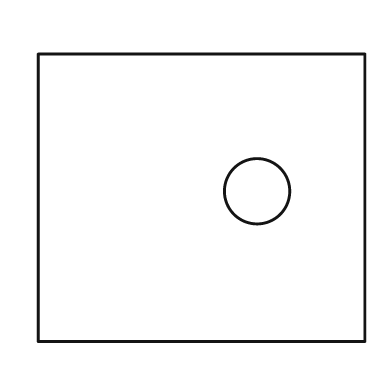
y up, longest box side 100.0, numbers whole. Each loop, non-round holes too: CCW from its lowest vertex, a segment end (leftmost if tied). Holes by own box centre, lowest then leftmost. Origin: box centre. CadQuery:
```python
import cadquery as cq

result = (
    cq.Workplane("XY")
    .moveTo(-50.0, -44.0)
    .lineTo(50.0, -44.0)
    .lineTo(50.0, 44.0)
    .lineTo(-50.0, 44.0)
    .close()
    .moveTo(17.0, 2.0)
    .circle(10.0)
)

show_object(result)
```